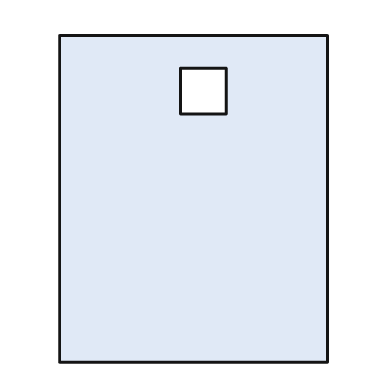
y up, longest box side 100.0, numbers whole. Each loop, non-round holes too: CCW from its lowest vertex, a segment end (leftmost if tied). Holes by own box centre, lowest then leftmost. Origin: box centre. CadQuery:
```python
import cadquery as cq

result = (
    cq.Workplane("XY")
    .moveTo(-41.0, -50.0)
    .lineTo(41.0, -50.0)
    .lineTo(41.0, 50.0)
    .lineTo(-41.0, 50.0)
    .close()
    .moveTo(-4.0, 26.0)
    .lineTo(10.0, 26.0)
    .lineTo(10.0, 40.0)
    .lineTo(-4.0, 40.0)
    .close()
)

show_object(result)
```